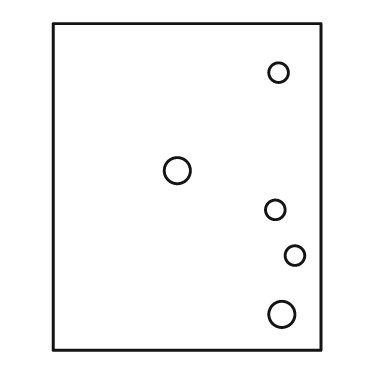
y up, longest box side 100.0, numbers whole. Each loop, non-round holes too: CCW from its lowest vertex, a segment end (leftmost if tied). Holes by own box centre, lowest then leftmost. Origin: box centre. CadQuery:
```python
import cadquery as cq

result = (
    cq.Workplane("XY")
    .moveTo(-41.0, -50.0)
    .lineTo(41.0, -50.0)
    .lineTo(41.0, 50.0)
    .lineTo(-41.0, 50.0)
    .close()
    .moveTo(29.0, -39.0)
    .circle(4.0)
    .moveTo(33.0, -21.0)
    .circle(3.0)
    .moveTo(27.0, -7.0)
    .circle(3.0)
    .moveTo(-3.0, 5.0)
    .circle(4.0)
    .moveTo(28.0, 35.0)
    .circle(3.0)
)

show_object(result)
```